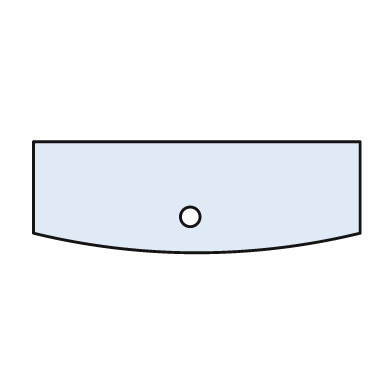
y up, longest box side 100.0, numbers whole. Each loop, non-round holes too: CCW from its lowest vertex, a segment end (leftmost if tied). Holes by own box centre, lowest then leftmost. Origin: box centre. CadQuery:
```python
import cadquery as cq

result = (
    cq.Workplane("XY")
    .moveTo(-50.0, -11.0)
    .threePointArc((0.0, -17.0), (50.0, -11.0))
    .lineTo(50.0, 17.0)
    .lineTo(-50.0, 17.0)
    .close()
    .moveTo(-2.0, -6.0)
    .circle(3.0)
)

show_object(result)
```